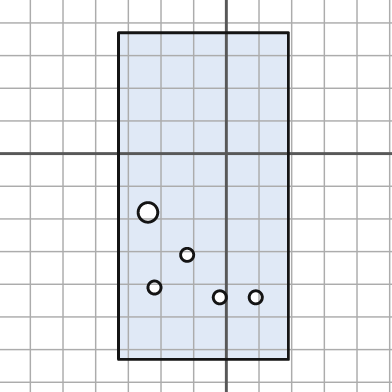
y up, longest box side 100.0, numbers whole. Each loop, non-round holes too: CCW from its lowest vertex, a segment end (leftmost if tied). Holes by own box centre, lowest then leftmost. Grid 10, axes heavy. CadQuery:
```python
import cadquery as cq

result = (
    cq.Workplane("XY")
    .moveTo(-33.0, -63.0)
    .lineTo(19.0, -63.0)
    .lineTo(19.0, 37.0)
    .lineTo(-33.0, 37.0)
    .close()
    .moveTo(-2.0, -44.0)
    .circle(2.0)
    .moveTo(9.0, -44.0)
    .circle(2.0)
    .moveTo(-22.0, -41.0)
    .circle(2.0)
    .moveTo(-12.0, -31.0)
    .circle(2.0)
    .moveTo(-24.0, -18.0)
    .circle(3.0)
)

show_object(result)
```